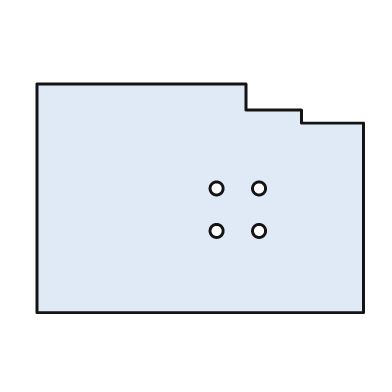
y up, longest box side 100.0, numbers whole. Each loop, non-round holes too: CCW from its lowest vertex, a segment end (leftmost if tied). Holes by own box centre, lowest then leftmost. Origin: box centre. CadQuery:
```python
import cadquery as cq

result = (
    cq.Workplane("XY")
    .moveTo(-50.0, -35.0)
    .lineTo(50.0, -35.0)
    .lineTo(50.0, 23.0)
    .lineTo(31.0, 23.0)
    .lineTo(31.0, 27.0)
    .lineTo(14.0, 27.0)
    .lineTo(14.0, 35.0)
    .lineTo(-50.0, 35.0)
    .close()
    .moveTo(5.0, -10.0)
    .circle(2.0)
    .moveTo(18.0, -10.0)
    .circle(2.0)
    .moveTo(5.0, 3.0)
    .circle(2.0)
    .moveTo(18.0, 3.0)
    .circle(2.0)
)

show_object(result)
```